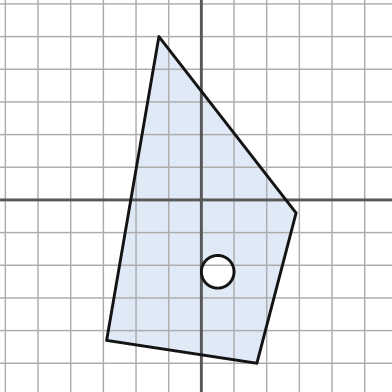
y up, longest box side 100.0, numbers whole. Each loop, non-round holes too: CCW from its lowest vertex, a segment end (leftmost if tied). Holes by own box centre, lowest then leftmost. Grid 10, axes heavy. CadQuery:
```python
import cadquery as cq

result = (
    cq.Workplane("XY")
    .moveTo(17.0, -50.0)
    .lineTo(29.0, -4.0)
    .lineTo(-13.0, 50.0)
    .lineTo(-29.0, -43.0)
    .close()
    .moveTo(5.0, -22.0)
    .circle(5.0)
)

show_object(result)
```